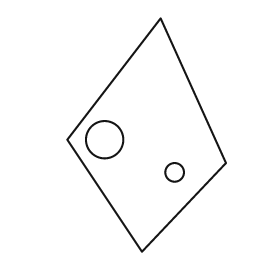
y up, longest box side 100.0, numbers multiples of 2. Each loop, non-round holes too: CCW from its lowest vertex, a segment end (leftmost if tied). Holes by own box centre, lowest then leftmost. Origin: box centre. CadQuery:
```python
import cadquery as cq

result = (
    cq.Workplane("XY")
    .moveTo(-2.0, -50.0)
    .lineTo(34.0, -12.0)
    .lineTo(6.0, 50.0)
    .lineTo(-34.0, -2.0)
    .close()
    .moveTo(12.0, -16.0)
    .circle(4.0)
    .moveTo(-18.0, -2.0)
    .circle(8.0)
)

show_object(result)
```